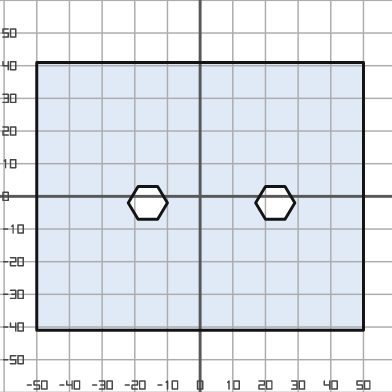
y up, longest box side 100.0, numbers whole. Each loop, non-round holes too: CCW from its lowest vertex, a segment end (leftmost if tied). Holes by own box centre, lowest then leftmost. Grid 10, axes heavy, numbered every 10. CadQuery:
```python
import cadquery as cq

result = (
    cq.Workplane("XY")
    .moveTo(-50.0, -41.0)
    .lineTo(50.0, -41.0)
    .lineTo(50.0, 41.0)
    .lineTo(-50.0, 41.0)
    .close()
    .moveTo(-19.0, -7.0)
    .lineTo(-13.0, -7.0)
    .lineTo(-10.0, -2.0)
    .lineTo(-13.0, 3.0)
    .lineTo(-19.0, 3.0)
    .lineTo(-22.0, -2.0)
    .close()
    .moveTo(20.0, -7.0)
    .lineTo(26.0, -7.0)
    .lineTo(29.0, -2.0)
    .lineTo(26.0, 3.0)
    .lineTo(20.0, 3.0)
    .lineTo(17.0, -2.0)
    .close()
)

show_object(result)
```